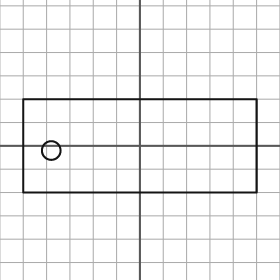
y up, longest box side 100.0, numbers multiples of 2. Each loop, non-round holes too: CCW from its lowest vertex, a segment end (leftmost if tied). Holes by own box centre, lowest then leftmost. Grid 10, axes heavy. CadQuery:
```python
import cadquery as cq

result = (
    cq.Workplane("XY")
    .moveTo(-50.0, -20.0)
    .lineTo(50.0, -20.0)
    .lineTo(50.0, 20.0)
    .lineTo(-50.0, 20.0)
    .close()
    .moveTo(-38.0, -2.0)
    .circle(4.0)
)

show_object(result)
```